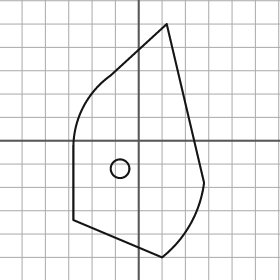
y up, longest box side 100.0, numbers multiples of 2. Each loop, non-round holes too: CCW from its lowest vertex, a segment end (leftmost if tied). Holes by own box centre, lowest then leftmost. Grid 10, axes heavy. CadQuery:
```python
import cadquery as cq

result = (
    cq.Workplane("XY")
    .moveTo(10.0, -50.0)
    .threePointArc((22.0, -36.0), (28.0, -18.0))
    .lineTo(12.0, 50.0)
    .lineTo(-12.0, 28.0)
    .threePointArc((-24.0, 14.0), (-28.0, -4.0))
    .lineTo(-28.0, -34.0)
    .close()
    .moveTo(-8.0, -12.0)
    .circle(4.0)
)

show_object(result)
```